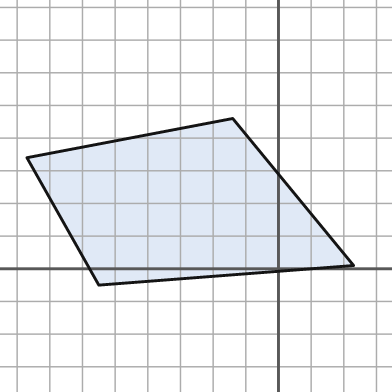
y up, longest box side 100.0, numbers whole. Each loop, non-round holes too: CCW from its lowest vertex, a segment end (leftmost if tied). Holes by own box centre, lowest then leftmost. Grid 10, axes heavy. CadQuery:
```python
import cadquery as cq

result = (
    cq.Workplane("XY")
    .moveTo(-55.0, -5.0)
    .lineTo(23.0, 1.0)
    .lineTo(-14.0, 46.0)
    .lineTo(-77.0, 34.0)
    .close()
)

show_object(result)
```